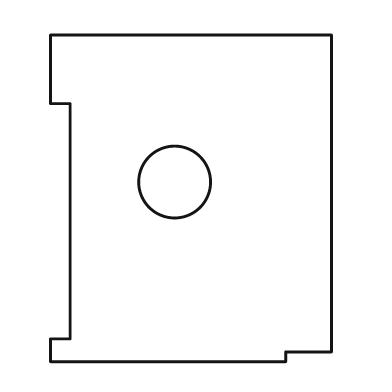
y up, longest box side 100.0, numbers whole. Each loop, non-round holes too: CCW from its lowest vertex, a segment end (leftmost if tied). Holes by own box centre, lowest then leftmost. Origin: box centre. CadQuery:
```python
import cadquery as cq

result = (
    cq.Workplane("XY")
    .moveTo(-43.0, -50.0)
    .lineTo(29.0, -50.0)
    .lineTo(29.0, -47.0)
    .lineTo(43.0, -47.0)
    .lineTo(43.0, 50.0)
    .lineTo(-43.0, 50.0)
    .lineTo(-43.0, 29.0)
    .lineTo(-37.0, 29.0)
    .lineTo(-37.0, -43.0)
    .lineTo(-43.0, -43.0)
    .close()
    .moveTo(-5.0, 5.0)
    .circle(11.0)
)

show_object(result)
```